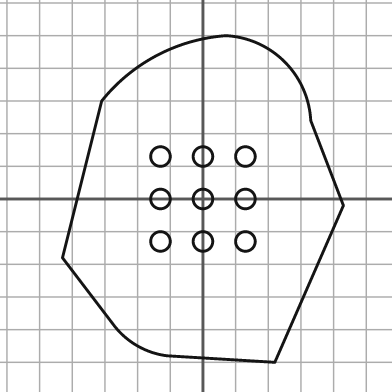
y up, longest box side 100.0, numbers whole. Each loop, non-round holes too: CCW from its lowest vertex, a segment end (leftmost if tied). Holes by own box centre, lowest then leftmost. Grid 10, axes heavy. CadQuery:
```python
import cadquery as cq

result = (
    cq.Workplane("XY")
    .moveTo(22.0, -50.0)
    .lineTo(43.0, -2.0)
    .lineTo(33.0, 24.0)
    .threePointArc((25.0, 42.0), (7.0, 50.0))
    .threePointArc((-14.0, 44.0), (-31.0, 30.0))
    .lineTo(-43.0, -18.0)
    .lineTo(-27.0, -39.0)
    .threePointArc((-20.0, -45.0), (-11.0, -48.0))
    .close()
    .moveTo(-13.0, -13.0)
    .circle(3.0)
    .moveTo(0.0, -13.0)
    .circle(3.0)
    .moveTo(13.0, -13.0)
    .circle(3.0)
    .moveTo(-13.0, 0.0)
    .circle(3.0)
    .moveTo(0.0, 0.0)
    .circle(3.0)
    .moveTo(13.0, 0.0)
    .circle(3.0)
    .moveTo(-13.0, 13.0)
    .circle(3.0)
    .moveTo(0.0, 13.0)
    .circle(3.0)
    .moveTo(13.0, 13.0)
    .circle(3.0)
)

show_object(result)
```